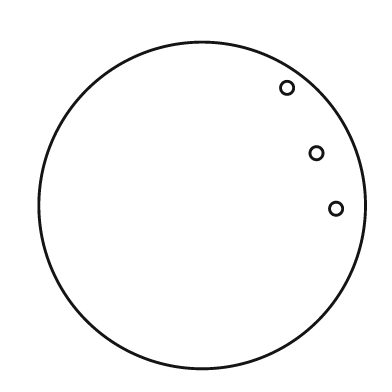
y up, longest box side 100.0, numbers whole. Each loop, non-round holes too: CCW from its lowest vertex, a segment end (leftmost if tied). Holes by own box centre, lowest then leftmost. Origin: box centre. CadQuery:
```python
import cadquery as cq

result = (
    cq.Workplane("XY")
    .moveTo(0.0, 0.0)
    .circle(50.0)
    .moveTo(41.0, -1.0)
    .circle(2.0)
    .moveTo(35.0, 16.0)
    .circle(2.0)
    .moveTo(26.0, 36.0)
    .circle(2.0)
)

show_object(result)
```